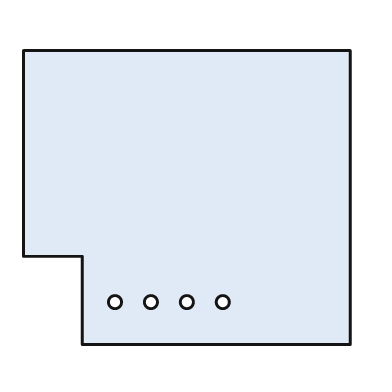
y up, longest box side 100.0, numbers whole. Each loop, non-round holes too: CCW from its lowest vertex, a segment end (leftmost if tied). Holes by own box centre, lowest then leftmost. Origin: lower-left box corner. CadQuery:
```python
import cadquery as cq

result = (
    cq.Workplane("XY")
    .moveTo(18.0, 0.0)
    .lineTo(100.0, 0.0)
    .lineTo(100.0, 90.0)
    .lineTo(0.0, 90.0)
    .lineTo(0.0, 27.0)
    .lineTo(18.0, 27.0)
    .close()
    .moveTo(28.0, 13.0)
    .circle(2.0)
    .moveTo(39.0, 13.0)
    .circle(2.0)
    .moveTo(50.0, 13.0)
    .circle(2.0)
    .moveTo(61.0, 13.0)
    .circle(2.0)
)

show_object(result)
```